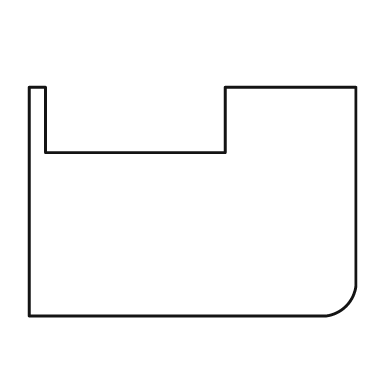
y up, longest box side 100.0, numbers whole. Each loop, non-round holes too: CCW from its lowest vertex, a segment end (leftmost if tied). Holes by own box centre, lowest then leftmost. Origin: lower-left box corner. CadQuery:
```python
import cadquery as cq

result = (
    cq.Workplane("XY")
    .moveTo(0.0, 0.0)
    .lineTo(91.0, 0.0)
    .threePointArc((97.0, 3.0), (100.0, 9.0))
    .lineTo(100.0, 70.0)
    .lineTo(60.0, 70.0)
    .lineTo(60.0, 50.0)
    .lineTo(5.0, 50.0)
    .lineTo(5.0, 70.0)
    .lineTo(0.0, 70.0)
    .close()
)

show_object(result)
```